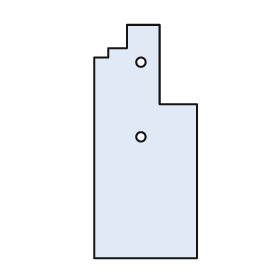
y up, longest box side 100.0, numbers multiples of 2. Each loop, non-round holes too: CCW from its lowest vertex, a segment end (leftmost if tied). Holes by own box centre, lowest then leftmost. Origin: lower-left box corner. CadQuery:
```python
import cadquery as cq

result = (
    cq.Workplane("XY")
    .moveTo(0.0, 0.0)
    .lineTo(44.0, 0.0)
    .lineTo(44.0, 66.0)
    .lineTo(28.0, 66.0)
    .lineTo(28.0, 100.0)
    .lineTo(14.0, 100.0)
    .lineTo(14.0, 90.0)
    .lineTo(6.0, 90.0)
    .lineTo(6.0, 86.0)
    .lineTo(0.0, 86.0)
    .close()
    .moveTo(20.0, 52.0)
    .circle(2.0)
    .moveTo(20.0, 84.0)
    .circle(2.0)
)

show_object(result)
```